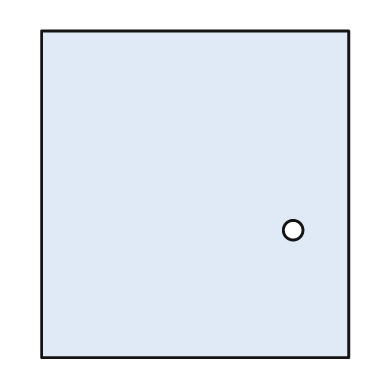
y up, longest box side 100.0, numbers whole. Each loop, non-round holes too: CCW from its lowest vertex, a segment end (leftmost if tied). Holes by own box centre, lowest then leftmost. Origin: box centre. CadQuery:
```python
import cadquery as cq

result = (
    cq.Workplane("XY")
    .moveTo(-47.0, -50.0)
    .lineTo(47.0, -50.0)
    .lineTo(47.0, 50.0)
    .lineTo(-47.0, 50.0)
    .close()
    .moveTo(30.0, -11.0)
    .circle(3.0)
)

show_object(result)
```